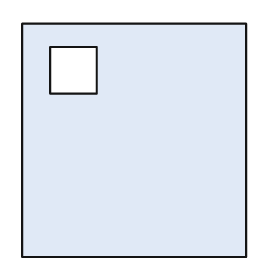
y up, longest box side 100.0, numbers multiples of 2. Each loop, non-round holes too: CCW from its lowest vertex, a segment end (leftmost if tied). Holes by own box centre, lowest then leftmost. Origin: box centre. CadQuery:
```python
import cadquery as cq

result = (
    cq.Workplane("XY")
    .moveTo(-48.0, -50.0)
    .lineTo(48.0, -50.0)
    .lineTo(48.0, 50.0)
    .lineTo(-48.0, 50.0)
    .close()
    .moveTo(-36.0, 20.0)
    .lineTo(-16.0, 20.0)
    .lineTo(-16.0, 40.0)
    .lineTo(-36.0, 40.0)
    .close()
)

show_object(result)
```